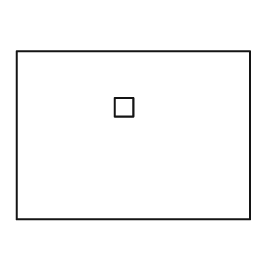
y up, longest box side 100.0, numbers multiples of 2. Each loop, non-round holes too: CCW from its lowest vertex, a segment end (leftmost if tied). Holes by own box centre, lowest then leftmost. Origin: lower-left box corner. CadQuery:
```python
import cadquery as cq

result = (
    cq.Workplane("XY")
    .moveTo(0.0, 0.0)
    .lineTo(100.0, 0.0)
    .lineTo(100.0, 72.0)
    .lineTo(0.0, 72.0)
    .close()
    .moveTo(42.0, 44.0)
    .lineTo(50.0, 44.0)
    .lineTo(50.0, 52.0)
    .lineTo(42.0, 52.0)
    .close()
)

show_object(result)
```